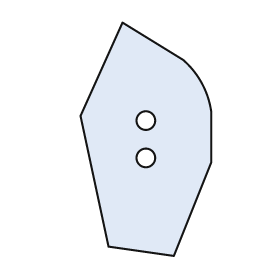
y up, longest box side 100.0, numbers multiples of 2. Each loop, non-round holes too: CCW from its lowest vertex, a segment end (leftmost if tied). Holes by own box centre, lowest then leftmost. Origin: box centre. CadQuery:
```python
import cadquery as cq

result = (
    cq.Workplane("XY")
    .moveTo(12.0, -50.0)
    .lineTo(28.0, -10.0)
    .lineTo(28.0, 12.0)
    .threePointArc((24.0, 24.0), (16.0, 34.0))
    .lineTo(-10.0, 50.0)
    .lineTo(-28.0, 10.0)
    .lineTo(-16.0, -46.0)
    .close()
    .moveTo(0.0, -8.0)
    .circle(4.0)
    .moveTo(0.0, 8.0)
    .circle(4.0)
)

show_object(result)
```